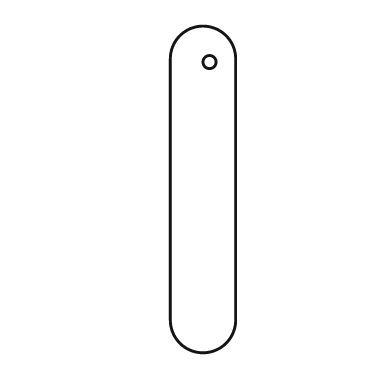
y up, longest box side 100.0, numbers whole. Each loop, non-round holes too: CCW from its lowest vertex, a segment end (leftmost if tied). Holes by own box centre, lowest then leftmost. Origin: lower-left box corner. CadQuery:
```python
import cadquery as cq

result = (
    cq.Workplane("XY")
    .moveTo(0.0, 10.0)
    .threePointArc((10.0, 0.0), (20.0, 10.0))
    .lineTo(20.0, 90.0)
    .threePointArc((10.0, 100.0), (0.0, 90.0))
    .close()
    .moveTo(12.0, 89.0)
    .circle(2.0)
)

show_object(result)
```